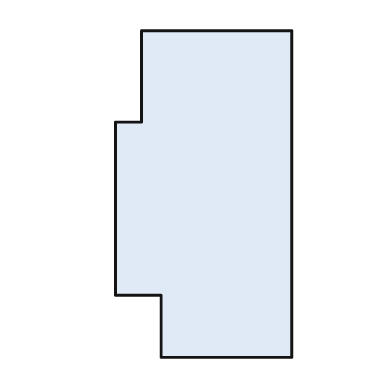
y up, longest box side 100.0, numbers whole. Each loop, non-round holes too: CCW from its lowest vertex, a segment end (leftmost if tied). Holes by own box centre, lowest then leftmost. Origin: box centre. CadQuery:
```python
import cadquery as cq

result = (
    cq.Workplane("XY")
    .moveTo(-13.0, -50.0)
    .lineTo(27.0, -50.0)
    .lineTo(27.0, 50.0)
    .lineTo(-19.0, 50.0)
    .lineTo(-19.0, 22.0)
    .lineTo(-27.0, 22.0)
    .lineTo(-27.0, -31.0)
    .lineTo(-13.0, -31.0)
    .close()
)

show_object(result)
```